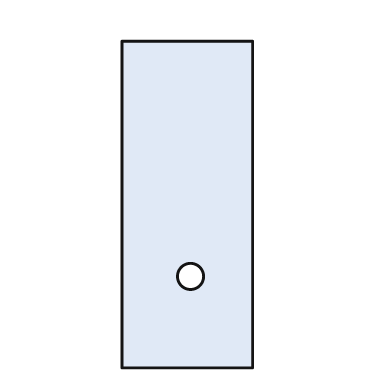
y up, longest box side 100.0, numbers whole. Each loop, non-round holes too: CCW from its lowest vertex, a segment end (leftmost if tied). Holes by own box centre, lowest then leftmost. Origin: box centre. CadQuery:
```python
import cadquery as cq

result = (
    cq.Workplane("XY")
    .moveTo(-20.0, -50.0)
    .lineTo(20.0, -50.0)
    .lineTo(20.0, 50.0)
    .lineTo(-20.0, 50.0)
    .close()
    .moveTo(1.0, -22.0)
    .circle(4.0)
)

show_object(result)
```